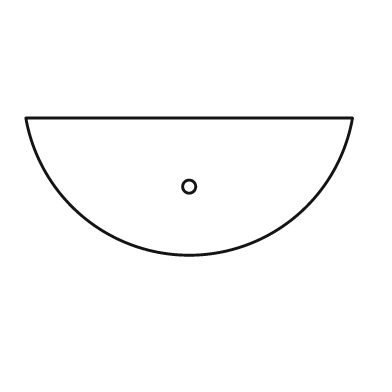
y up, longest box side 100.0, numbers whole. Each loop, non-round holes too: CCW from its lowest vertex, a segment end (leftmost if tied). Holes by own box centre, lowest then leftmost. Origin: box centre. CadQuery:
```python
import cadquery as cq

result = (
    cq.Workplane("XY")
    .moveTo(-50.0, 21.0)
    .threePointArc((0.0, -21.0), (50.0, 21.0))
    .close()
    .moveTo(0.0, 0.0)
    .circle(2.0)
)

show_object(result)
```